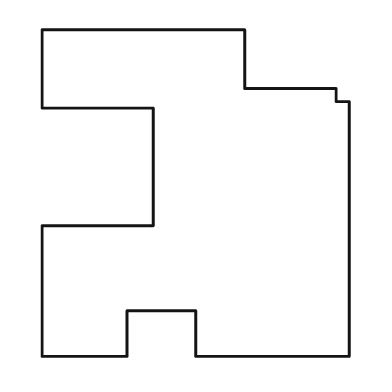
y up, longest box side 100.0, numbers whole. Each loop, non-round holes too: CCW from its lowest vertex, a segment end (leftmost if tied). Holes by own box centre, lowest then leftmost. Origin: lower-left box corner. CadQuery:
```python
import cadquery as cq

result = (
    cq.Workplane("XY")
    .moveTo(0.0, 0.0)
    .lineTo(26.0, 0.0)
    .lineTo(26.0, 14.0)
    .lineTo(47.0, 14.0)
    .lineTo(47.0, 0.0)
    .lineTo(94.0, 0.0)
    .lineTo(94.0, 78.0)
    .lineTo(90.0, 78.0)
    .lineTo(90.0, 82.0)
    .lineTo(62.0, 82.0)
    .lineTo(62.0, 100.0)
    .lineTo(0.0, 100.0)
    .lineTo(0.0, 76.0)
    .lineTo(34.0, 76.0)
    .lineTo(34.0, 40.0)
    .lineTo(0.0, 40.0)
    .close()
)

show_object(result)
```